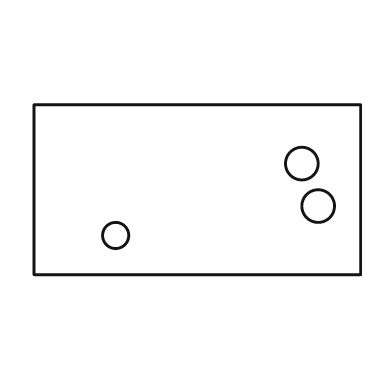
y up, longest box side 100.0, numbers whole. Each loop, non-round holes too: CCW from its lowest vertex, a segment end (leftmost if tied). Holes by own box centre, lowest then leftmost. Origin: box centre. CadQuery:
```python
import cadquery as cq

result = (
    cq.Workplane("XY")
    .moveTo(-50.0, -26.0)
    .lineTo(50.0, -26.0)
    .lineTo(50.0, 26.0)
    .lineTo(-50.0, 26.0)
    .close()
    .moveTo(-25.0, -14.0)
    .circle(4.0)
    .moveTo(37.0, -5.0)
    .circle(5.0)
    .moveTo(32.0, 8.0)
    .circle(5.0)
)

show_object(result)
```